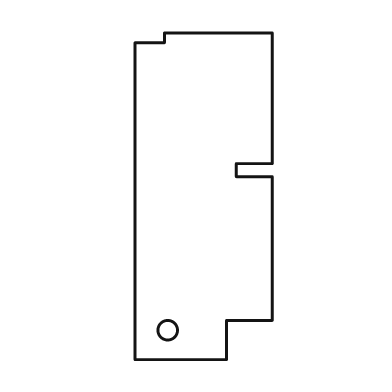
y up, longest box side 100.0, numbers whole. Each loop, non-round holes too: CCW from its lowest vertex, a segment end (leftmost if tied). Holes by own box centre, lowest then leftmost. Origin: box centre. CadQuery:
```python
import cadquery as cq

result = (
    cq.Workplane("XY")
    .moveTo(-21.0, -50.0)
    .lineTo(7.0, -50.0)
    .lineTo(7.0, -38.0)
    .lineTo(21.0, -38.0)
    .lineTo(21.0, 6.0)
    .lineTo(10.0, 6.0)
    .lineTo(10.0, 10.0)
    .lineTo(21.0, 10.0)
    .lineTo(21.0, 50.0)
    .lineTo(-12.0, 50.0)
    .lineTo(-12.0, 47.0)
    .lineTo(-21.0, 47.0)
    .close()
    .moveTo(-11.0, -41.0)
    .circle(3.0)
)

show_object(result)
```